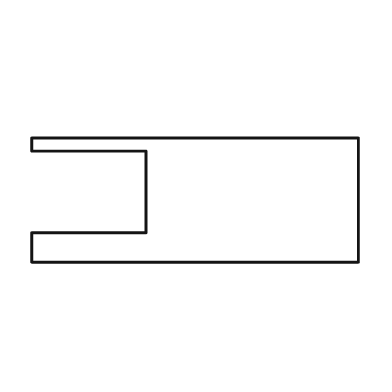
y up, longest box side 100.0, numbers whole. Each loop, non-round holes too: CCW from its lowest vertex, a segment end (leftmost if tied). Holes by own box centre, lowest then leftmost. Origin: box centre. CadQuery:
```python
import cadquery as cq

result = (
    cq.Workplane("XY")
    .moveTo(-50.0, -19.0)
    .lineTo(50.0, -19.0)
    .lineTo(50.0, 19.0)
    .lineTo(-50.0, 19.0)
    .lineTo(-50.0, 15.0)
    .lineTo(-15.0, 15.0)
    .lineTo(-15.0, -10.0)
    .lineTo(-50.0, -10.0)
    .close()
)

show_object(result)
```